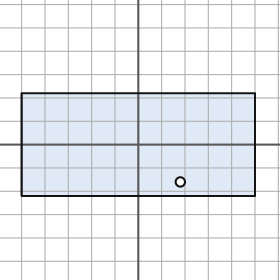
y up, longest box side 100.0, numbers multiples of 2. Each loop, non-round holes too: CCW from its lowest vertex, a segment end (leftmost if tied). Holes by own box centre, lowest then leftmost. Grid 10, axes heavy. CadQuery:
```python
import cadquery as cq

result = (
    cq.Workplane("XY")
    .moveTo(-50.0, -22.0)
    .lineTo(50.0, -22.0)
    .lineTo(50.0, 22.0)
    .lineTo(-50.0, 22.0)
    .close()
    .moveTo(18.0, -16.0)
    .circle(2.0)
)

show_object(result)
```